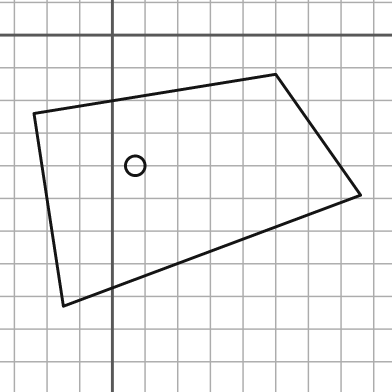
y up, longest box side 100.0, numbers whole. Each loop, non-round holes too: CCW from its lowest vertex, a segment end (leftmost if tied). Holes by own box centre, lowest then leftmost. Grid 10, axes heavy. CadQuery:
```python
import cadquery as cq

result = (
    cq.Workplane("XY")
    .moveTo(-15.0, -83.0)
    .lineTo(76.0, -49.0)
    .lineTo(50.0, -12.0)
    .lineTo(-24.0, -24.0)
    .close()
    .moveTo(7.0, -40.0)
    .circle(3.0)
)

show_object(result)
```